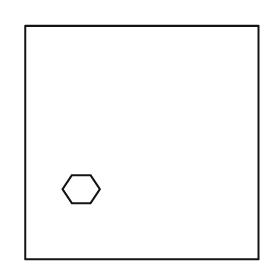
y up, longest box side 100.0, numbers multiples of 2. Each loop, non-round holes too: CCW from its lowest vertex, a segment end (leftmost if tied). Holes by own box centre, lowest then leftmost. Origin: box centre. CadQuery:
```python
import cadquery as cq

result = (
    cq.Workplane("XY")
    .moveTo(-50.0, -50.0)
    .lineTo(50.0, -50.0)
    .lineTo(50.0, 50.0)
    .lineTo(-50.0, 50.0)
    .close()
    .moveTo(-30.0, -26.0)
    .lineTo(-22.0, -26.0)
    .lineTo(-18.0, -20.0)
    .lineTo(-22.0, -14.0)
    .lineTo(-30.0, -14.0)
    .lineTo(-34.0, -20.0)
    .close()
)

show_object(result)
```